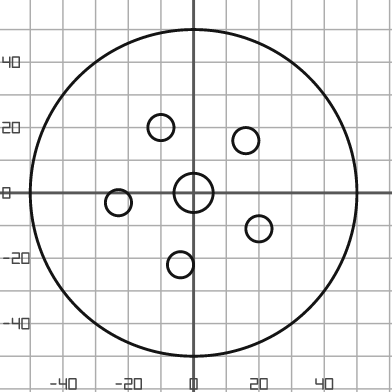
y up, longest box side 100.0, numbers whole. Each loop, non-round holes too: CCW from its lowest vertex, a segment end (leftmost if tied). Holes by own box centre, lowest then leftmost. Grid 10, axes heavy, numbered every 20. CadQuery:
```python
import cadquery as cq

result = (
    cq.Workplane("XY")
    .moveTo(0.0, 0.0)
    .circle(50.0)
    .moveTo(-4.0, -22.0)
    .circle(4.0)
    .moveTo(20.0, -11.0)
    .circle(4.0)
    .moveTo(-23.0, -3.0)
    .circle(4.0)
    .moveTo(0.0, 0.0)
    .circle(6.0)
    .moveTo(16.0, 16.0)
    .circle(4.0)
    .moveTo(-10.0, 20.0)
    .circle(4.0)
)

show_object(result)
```